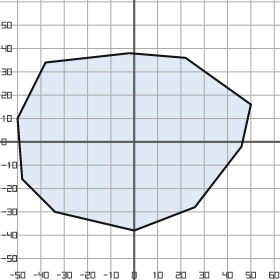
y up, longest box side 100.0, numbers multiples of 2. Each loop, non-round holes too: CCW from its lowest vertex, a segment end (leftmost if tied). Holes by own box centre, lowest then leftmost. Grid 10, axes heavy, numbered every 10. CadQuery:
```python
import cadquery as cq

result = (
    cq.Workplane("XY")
    .moveTo(0.0, -38.0)
    .lineTo(26.0, -28.0)
    .lineTo(46.0, -2.0)
    .lineTo(50.0, 16.0)
    .lineTo(22.0, 36.0)
    .lineTo(-2.0, 38.0)
    .lineTo(-38.0, 34.0)
    .lineTo(-50.0, 10.0)
    .lineTo(-48.0, -16.0)
    .lineTo(-34.0, -30.0)
    .close()
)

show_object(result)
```